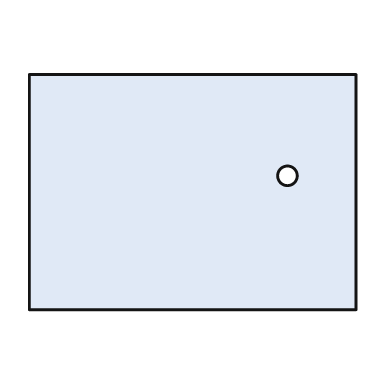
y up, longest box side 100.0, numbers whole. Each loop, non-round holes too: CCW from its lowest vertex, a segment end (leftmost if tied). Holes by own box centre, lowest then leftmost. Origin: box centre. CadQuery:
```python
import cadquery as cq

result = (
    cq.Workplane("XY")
    .moveTo(-50.0, -36.0)
    .lineTo(50.0, -36.0)
    .lineTo(50.0, 36.0)
    .lineTo(-50.0, 36.0)
    .close()
    .moveTo(29.0, 5.0)
    .circle(3.0)
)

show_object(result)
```